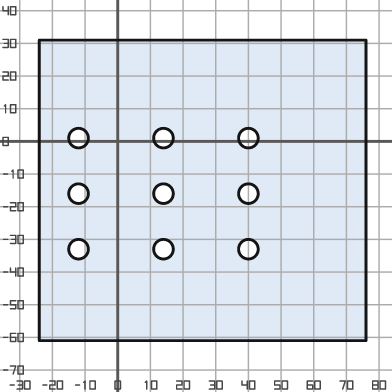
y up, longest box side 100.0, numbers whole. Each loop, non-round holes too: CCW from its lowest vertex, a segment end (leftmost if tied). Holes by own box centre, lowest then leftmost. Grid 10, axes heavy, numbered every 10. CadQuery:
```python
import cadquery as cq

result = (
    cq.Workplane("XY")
    .moveTo(-24.0, -61.0)
    .lineTo(76.0, -61.0)
    .lineTo(76.0, 31.0)
    .lineTo(-24.0, 31.0)
    .close()
    .moveTo(-12.0, -33.0)
    .circle(3.0)
    .moveTo(14.0, -33.0)
    .circle(3.0)
    .moveTo(40.0, -33.0)
    .circle(3.0)
    .moveTo(-12.0, -16.0)
    .circle(3.0)
    .moveTo(14.0, -16.0)
    .circle(3.0)
    .moveTo(40.0, -16.0)
    .circle(3.0)
    .moveTo(-12.0, 1.0)
    .circle(3.0)
    .moveTo(14.0, 1.0)
    .circle(3.0)
    .moveTo(40.0, 1.0)
    .circle(3.0)
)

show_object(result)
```